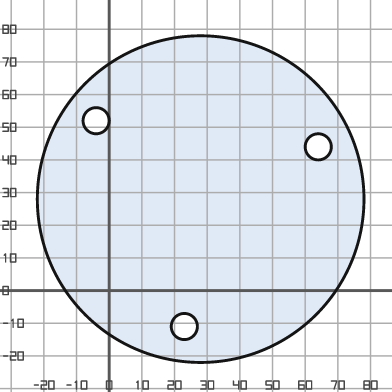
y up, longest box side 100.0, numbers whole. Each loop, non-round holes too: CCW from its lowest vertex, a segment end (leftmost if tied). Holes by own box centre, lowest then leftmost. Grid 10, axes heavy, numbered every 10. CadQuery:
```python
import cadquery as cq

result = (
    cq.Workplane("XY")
    .moveTo(28.0, 28.0)
    .circle(50.0)
    .moveTo(23.0, -11.0)
    .circle(4.0)
    .moveTo(64.0, 44.0)
    .circle(4.0)
    .moveTo(-4.0, 52.0)
    .circle(4.0)
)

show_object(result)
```